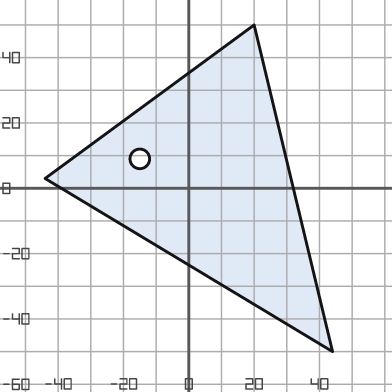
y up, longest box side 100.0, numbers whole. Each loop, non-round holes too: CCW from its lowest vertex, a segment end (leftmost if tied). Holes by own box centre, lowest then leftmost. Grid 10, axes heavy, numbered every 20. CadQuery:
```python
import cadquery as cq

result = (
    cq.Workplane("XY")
    .moveTo(44.0, -50.0)
    .lineTo(20.0, 50.0)
    .lineTo(-44.0, 3.0)
    .close()
    .moveTo(-15.0, 9.0)
    .circle(3.0)
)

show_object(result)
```